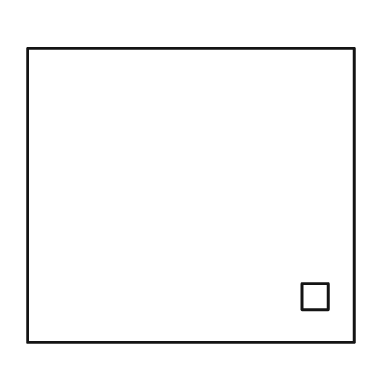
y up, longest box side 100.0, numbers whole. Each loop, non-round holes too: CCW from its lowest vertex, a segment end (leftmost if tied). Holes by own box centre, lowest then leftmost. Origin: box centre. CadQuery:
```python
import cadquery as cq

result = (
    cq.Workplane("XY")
    .moveTo(-50.0, -45.0)
    .lineTo(50.0, -45.0)
    .lineTo(50.0, 45.0)
    .lineTo(-50.0, 45.0)
    .close()
    .moveTo(34.0, -35.0)
    .lineTo(42.0, -35.0)
    .lineTo(42.0, -27.0)
    .lineTo(34.0, -27.0)
    .close()
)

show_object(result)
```